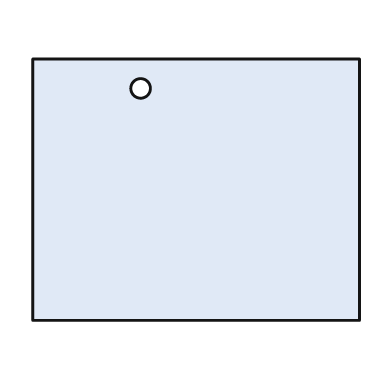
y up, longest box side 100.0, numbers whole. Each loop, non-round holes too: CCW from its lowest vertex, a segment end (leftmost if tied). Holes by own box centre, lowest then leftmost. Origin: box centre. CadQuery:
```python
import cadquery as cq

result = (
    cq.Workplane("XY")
    .moveTo(-50.0, -40.0)
    .lineTo(50.0, -40.0)
    .lineTo(50.0, 40.0)
    .lineTo(-50.0, 40.0)
    .close()
    .moveTo(-17.0, 31.0)
    .circle(3.0)
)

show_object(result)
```